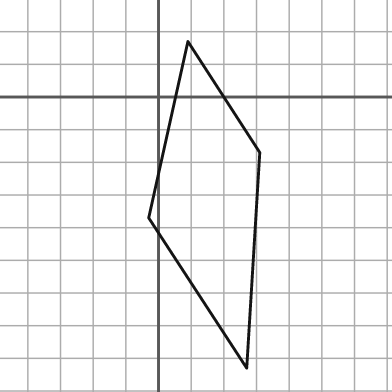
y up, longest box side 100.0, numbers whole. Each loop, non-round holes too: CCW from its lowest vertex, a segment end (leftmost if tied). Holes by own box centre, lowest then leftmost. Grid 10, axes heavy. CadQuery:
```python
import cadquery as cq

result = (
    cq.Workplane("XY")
    .moveTo(27.0, -83.0)
    .lineTo(31.0, -17.0)
    .lineTo(9.0, 17.0)
    .lineTo(-3.0, -37.0)
    .close()
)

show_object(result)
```